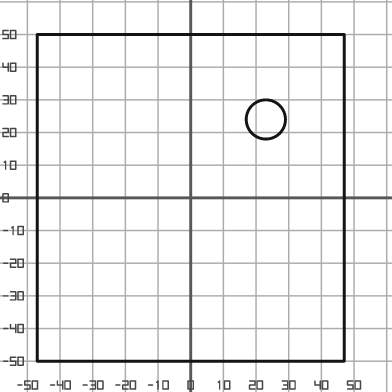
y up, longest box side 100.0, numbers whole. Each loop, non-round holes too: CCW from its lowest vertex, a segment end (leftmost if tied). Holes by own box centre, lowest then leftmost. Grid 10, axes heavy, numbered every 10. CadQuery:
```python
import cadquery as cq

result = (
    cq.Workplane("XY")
    .moveTo(-47.0, -50.0)
    .lineTo(47.0, -50.0)
    .lineTo(47.0, 50.0)
    .lineTo(-47.0, 50.0)
    .close()
    .moveTo(23.0, 24.0)
    .circle(6.0)
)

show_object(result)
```